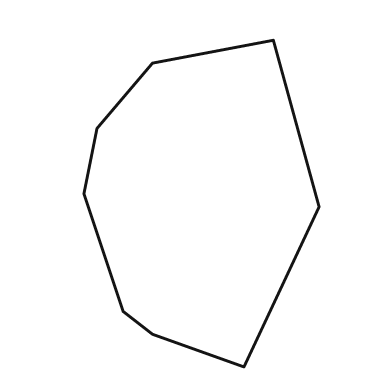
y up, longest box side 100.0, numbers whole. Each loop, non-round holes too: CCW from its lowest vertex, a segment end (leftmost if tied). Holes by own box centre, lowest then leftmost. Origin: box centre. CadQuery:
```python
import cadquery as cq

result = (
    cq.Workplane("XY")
    .moveTo(13.0, -50.0)
    .lineTo(36.0, -1.0)
    .lineTo(22.0, 50.0)
    .lineTo(-15.0, 43.0)
    .lineTo(-32.0, 23.0)
    .lineTo(-36.0, 3.0)
    .lineTo(-24.0, -33.0)
    .lineTo(-15.0, -40.0)
    .close()
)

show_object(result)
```